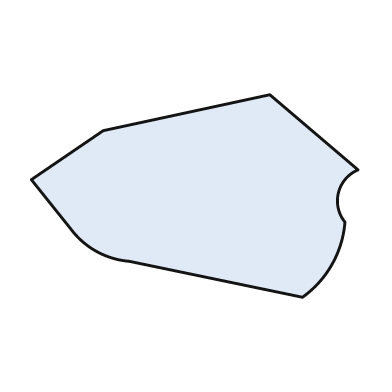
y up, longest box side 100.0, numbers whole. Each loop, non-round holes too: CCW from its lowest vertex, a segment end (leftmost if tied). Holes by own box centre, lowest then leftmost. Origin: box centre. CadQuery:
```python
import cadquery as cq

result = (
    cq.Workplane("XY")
    .moveTo(33.0, -31.0)
    .threePointArc((42.0, -21.0), (46.0, -8.0))
    .threePointArc((44.0, 1.0), (50.0, 8.0))
    .lineTo(23.0, 31.0)
    .lineTo(-28.0, 20.0)
    .lineTo(-50.0, 5.0)
    .lineTo(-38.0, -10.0)
    .threePointArc((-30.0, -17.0), (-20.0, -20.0))
    .close()
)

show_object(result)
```